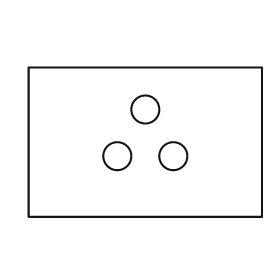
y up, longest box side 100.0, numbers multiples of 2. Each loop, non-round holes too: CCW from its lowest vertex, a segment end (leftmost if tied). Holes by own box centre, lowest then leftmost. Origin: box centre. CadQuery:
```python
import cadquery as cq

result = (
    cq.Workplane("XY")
    .moveTo(-50.0, -32.0)
    .lineTo(50.0, -32.0)
    .lineTo(50.0, 32.0)
    .lineTo(-50.0, 32.0)
    .close()
    .moveTo(-12.0, -6.0)
    .circle(6.0)
    .moveTo(12.0, -6.0)
    .circle(6.0)
    .moveTo(0.0, 14.0)
    .circle(6.0)
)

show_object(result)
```